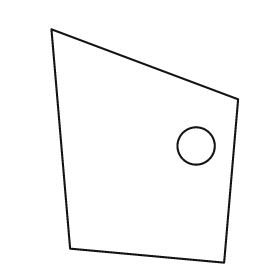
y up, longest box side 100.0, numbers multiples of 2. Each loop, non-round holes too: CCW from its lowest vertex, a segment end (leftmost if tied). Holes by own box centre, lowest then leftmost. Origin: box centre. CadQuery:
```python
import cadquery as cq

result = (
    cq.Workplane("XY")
    .moveTo(34.0, -50.0)
    .lineTo(40.0, 20.0)
    .lineTo(-40.0, 50.0)
    .lineTo(-32.0, -44.0)
    .close()
    .moveTo(22.0, 0.0)
    .circle(8.0)
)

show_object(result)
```